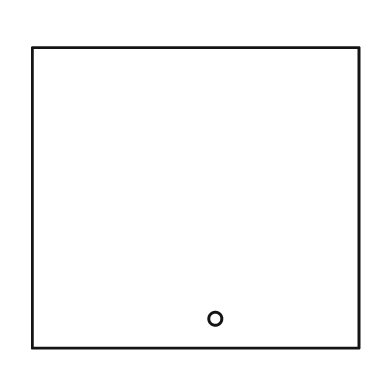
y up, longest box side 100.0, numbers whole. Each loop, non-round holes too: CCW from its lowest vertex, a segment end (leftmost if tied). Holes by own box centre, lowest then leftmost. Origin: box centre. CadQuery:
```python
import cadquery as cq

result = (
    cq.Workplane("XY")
    .moveTo(-50.0, -46.0)
    .lineTo(50.0, -46.0)
    .lineTo(50.0, 46.0)
    .lineTo(-50.0, 46.0)
    .close()
    .moveTo(6.0, -37.0)
    .circle(2.0)
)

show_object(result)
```